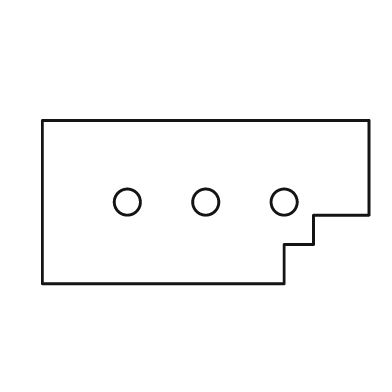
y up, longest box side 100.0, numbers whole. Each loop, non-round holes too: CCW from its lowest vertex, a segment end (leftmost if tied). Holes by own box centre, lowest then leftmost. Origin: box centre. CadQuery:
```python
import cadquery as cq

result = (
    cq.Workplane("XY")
    .moveTo(-50.0, -25.0)
    .lineTo(24.0, -25.0)
    .lineTo(24.0, -13.0)
    .lineTo(33.0, -13.0)
    .lineTo(33.0, -4.0)
    .lineTo(50.0, -4.0)
    .lineTo(50.0, 25.0)
    .lineTo(-50.0, 25.0)
    .close()
    .moveTo(-24.0, 0.0)
    .circle(4.0)
    .moveTo(0.0, 0.0)
    .circle(4.0)
    .moveTo(24.0, 0.0)
    .circle(4.0)
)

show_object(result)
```